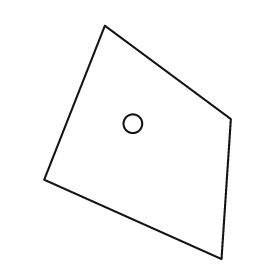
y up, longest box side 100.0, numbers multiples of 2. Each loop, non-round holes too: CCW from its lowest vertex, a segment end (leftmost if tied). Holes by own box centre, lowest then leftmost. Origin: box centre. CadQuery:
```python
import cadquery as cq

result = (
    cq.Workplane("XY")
    .moveTo(36.0, -50.0)
    .lineTo(40.0, 10.0)
    .lineTo(-14.0, 50.0)
    .lineTo(-40.0, -16.0)
    .close()
    .moveTo(-2.0, 8.0)
    .circle(4.0)
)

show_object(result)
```